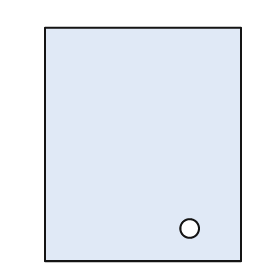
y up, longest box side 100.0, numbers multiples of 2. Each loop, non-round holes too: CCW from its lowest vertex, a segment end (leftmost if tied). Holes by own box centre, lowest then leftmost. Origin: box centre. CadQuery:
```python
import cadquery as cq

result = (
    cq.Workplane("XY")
    .moveTo(-42.0, -50.0)
    .lineTo(42.0, -50.0)
    .lineTo(42.0, 50.0)
    .lineTo(-42.0, 50.0)
    .close()
    .moveTo(20.0, -36.0)
    .circle(4.0)
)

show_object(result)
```